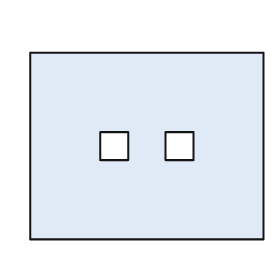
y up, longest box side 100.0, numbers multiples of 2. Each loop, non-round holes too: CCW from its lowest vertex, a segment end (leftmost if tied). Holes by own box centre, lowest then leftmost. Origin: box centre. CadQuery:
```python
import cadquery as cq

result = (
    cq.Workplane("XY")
    .moveTo(-50.0, -40.0)
    .lineTo(50.0, -40.0)
    .lineTo(50.0, 40.0)
    .lineTo(-50.0, 40.0)
    .close()
    .moveTo(-20.0, -6.0)
    .lineTo(-8.0, -6.0)
    .lineTo(-8.0, 6.0)
    .lineTo(-20.0, 6.0)
    .close()
    .moveTo(8.0, -6.0)
    .lineTo(20.0, -6.0)
    .lineTo(20.0, 6.0)
    .lineTo(8.0, 6.0)
    .close()
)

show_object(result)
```